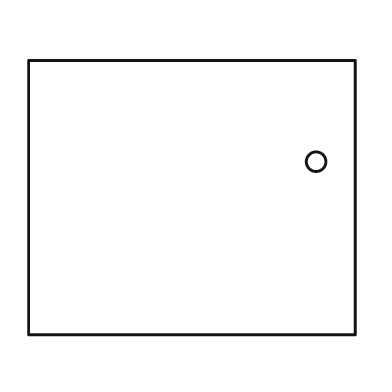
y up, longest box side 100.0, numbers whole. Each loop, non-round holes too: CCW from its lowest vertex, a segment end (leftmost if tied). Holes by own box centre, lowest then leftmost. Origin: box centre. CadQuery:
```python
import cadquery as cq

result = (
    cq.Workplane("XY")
    .moveTo(-50.0, -42.0)
    .lineTo(50.0, -42.0)
    .lineTo(50.0, 42.0)
    .lineTo(-50.0, 42.0)
    .close()
    .moveTo(38.0, 11.0)
    .circle(3.0)
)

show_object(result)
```